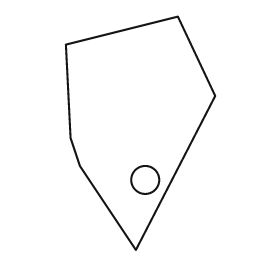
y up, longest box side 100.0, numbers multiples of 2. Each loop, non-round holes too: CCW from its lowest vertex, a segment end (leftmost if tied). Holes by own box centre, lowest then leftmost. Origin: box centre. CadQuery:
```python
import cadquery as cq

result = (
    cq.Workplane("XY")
    .moveTo(-2.0, -50.0)
    .lineTo(32.0, 16.0)
    .lineTo(16.0, 50.0)
    .lineTo(-32.0, 38.0)
    .lineTo(-30.0, -2.0)
    .lineTo(-26.0, -14.0)
    .close()
    .moveTo(2.0, -20.0)
    .circle(6.0)
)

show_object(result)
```